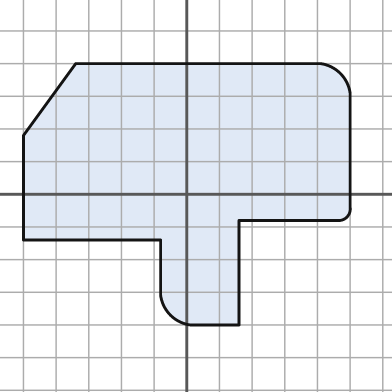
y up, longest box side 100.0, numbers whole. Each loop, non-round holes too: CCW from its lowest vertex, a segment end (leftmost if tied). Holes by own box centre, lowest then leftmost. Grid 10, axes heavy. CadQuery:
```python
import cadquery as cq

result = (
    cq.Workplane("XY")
    .moveTo(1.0, -40.0)
    .lineTo(16.0, -40.0)
    .lineTo(16.0, -8.0)
    .lineTo(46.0, -8.0)
    .threePointArc((49.0, -7.0), (50.0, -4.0))
    .lineTo(50.0, 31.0)
    .threePointArc((47.0, 37.0), (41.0, 40.0))
    .lineTo(-34.0, 40.0)
    .lineTo(-50.0, 18.0)
    .lineTo(-50.0, -14.0)
    .lineTo(-8.0, -14.0)
    .lineTo(-8.0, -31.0)
    .threePointArc((-5.0, -37.0), (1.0, -40.0))
    .close()
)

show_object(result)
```